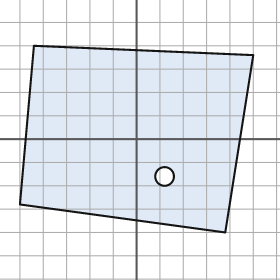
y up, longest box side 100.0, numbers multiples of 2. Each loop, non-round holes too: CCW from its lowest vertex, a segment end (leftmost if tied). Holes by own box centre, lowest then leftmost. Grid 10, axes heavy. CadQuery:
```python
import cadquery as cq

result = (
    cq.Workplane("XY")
    .moveTo(38.0, -40.0)
    .lineTo(50.0, 36.0)
    .lineTo(-44.0, 40.0)
    .lineTo(-50.0, -28.0)
    .close()
    .moveTo(12.0, -16.0)
    .circle(4.0)
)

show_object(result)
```